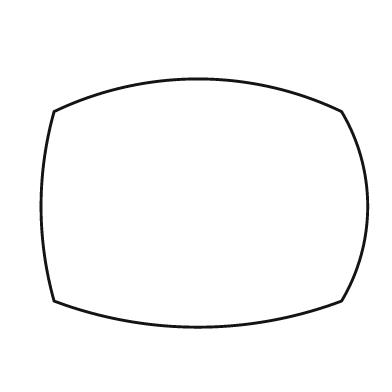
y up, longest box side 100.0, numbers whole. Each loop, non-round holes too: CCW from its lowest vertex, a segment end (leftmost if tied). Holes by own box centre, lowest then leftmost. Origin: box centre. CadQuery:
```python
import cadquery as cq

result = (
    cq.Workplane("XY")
    .moveTo(-46.0, -30.0)
    .threePointArc((-2.0, -38.0), (42.0, -30.0))
    .threePointArc((50.0, -1.0), (42.0, 28.0))
    .threePointArc((-2.0, 38.0), (-46.0, 28.0))
    .threePointArc((-50.0, -1.0), (-46.0, -30.0))
    .close()
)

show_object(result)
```